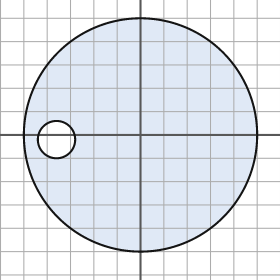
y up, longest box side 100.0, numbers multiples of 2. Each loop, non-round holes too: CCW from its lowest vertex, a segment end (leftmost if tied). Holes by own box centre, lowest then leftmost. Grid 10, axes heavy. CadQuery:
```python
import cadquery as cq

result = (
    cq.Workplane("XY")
    .moveTo(0.0, 0.0)
    .circle(50.0)
    .moveTo(-36.0, -2.0)
    .circle(8.0)
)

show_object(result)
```